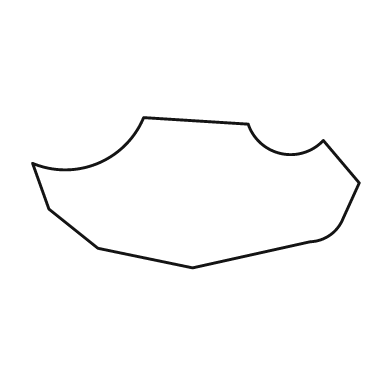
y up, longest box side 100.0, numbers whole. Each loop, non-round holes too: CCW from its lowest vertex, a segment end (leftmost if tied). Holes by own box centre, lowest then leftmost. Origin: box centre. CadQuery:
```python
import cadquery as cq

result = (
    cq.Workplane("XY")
    .moveTo(-1.0, -23.0)
    .lineTo(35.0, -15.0)
    .threePointArc((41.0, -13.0), (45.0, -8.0))
    .lineTo(50.0, 3.0)
    .lineTo(39.0, 16.0)
    .threePointArc((26.0, 12.0), (16.0, 21.0))
    .lineTo(-16.0, 23.0)
    .threePointArc((-30.0, 9.0), (-50.0, 9.0))
    .lineTo(-45.0, -5.0)
    .lineTo(-30.0, -17.0)
    .close()
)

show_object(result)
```